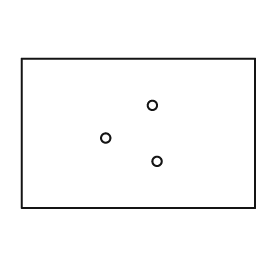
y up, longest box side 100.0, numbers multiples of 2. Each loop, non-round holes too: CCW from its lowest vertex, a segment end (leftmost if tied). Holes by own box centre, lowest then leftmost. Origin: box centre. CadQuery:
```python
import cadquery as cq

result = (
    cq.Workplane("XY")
    .moveTo(-50.0, -32.0)
    .lineTo(50.0, -32.0)
    .lineTo(50.0, 32.0)
    .lineTo(-50.0, 32.0)
    .close()
    .moveTo(8.0, -12.0)
    .circle(2.0)
    .moveTo(-14.0, -2.0)
    .circle(2.0)
    .moveTo(6.0, 12.0)
    .circle(2.0)
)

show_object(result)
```